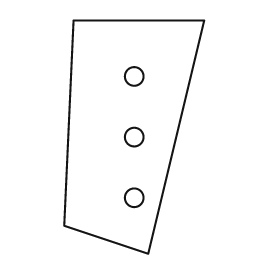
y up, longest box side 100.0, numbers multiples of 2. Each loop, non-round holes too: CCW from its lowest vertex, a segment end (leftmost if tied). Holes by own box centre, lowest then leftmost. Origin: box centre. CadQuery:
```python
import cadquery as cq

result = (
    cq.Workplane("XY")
    .moveTo(6.0, -50.0)
    .lineTo(30.0, 50.0)
    .lineTo(-26.0, 50.0)
    .lineTo(-30.0, -38.0)
    .close()
    .moveTo(0.0, -26.0)
    .circle(4.0)
    .moveTo(0.0, 0.0)
    .circle(4.0)
    .moveTo(0.0, 26.0)
    .circle(4.0)
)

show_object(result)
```